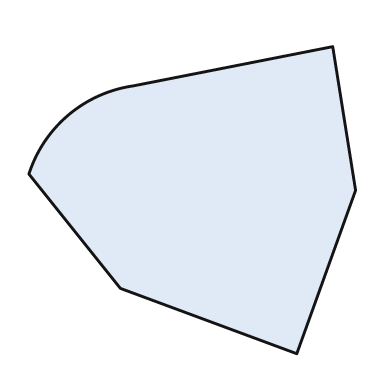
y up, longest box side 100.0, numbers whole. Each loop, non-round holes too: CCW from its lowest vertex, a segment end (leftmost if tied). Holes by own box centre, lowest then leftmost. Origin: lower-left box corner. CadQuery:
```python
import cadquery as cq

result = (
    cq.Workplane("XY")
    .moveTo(82.0, 0.0)
    .lineTo(100.0, 50.0)
    .lineTo(93.0, 94.0)
    .lineTo(32.0, 82.0)
    .threePointArc((12.0, 73.0), (0.0, 55.0))
    .lineTo(28.0, 20.0)
    .close()
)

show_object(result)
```